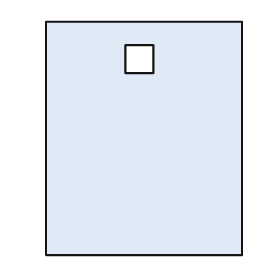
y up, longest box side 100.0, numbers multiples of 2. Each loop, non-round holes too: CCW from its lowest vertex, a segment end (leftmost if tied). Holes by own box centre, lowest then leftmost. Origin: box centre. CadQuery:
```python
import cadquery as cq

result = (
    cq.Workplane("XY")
    .moveTo(-42.0, -50.0)
    .lineTo(42.0, -50.0)
    .lineTo(42.0, 50.0)
    .lineTo(-42.0, 50.0)
    .close()
    .moveTo(-8.0, 28.0)
    .lineTo(4.0, 28.0)
    .lineTo(4.0, 40.0)
    .lineTo(-8.0, 40.0)
    .close()
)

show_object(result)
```